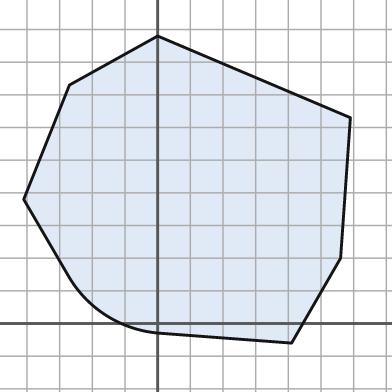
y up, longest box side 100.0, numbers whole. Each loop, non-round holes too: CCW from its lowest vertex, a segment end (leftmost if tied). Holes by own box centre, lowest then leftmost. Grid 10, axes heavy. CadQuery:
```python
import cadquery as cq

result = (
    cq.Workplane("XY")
    .moveTo(41.0, -6.0)
    .lineTo(56.0, 20.0)
    .lineTo(59.0, 63.0)
    .lineTo(0.0, 88.0)
    .lineTo(-27.0, 73.0)
    .lineTo(-41.0, 38.0)
    .lineTo(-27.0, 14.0)
    .threePointArc((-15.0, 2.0), (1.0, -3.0))
    .close()
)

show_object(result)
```